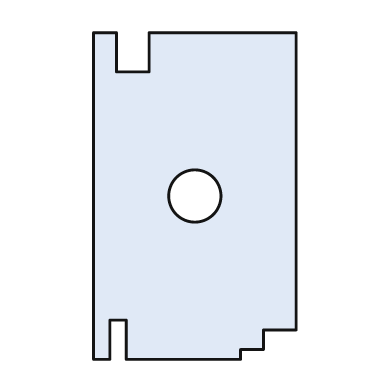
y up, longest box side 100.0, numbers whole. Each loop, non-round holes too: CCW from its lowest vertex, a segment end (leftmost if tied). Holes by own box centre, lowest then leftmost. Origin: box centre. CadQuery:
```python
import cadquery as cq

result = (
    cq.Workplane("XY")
    .moveTo(-31.0, -50.0)
    .lineTo(-26.0, -50.0)
    .lineTo(-26.0, -38.0)
    .lineTo(-21.0, -38.0)
    .lineTo(-21.0, -50.0)
    .lineTo(14.0, -50.0)
    .lineTo(14.0, -47.0)
    .lineTo(21.0, -47.0)
    .lineTo(21.0, -41.0)
    .lineTo(31.0, -41.0)
    .lineTo(31.0, 50.0)
    .lineTo(-14.0, 50.0)
    .lineTo(-14.0, 38.0)
    .lineTo(-24.0, 38.0)
    .lineTo(-24.0, 50.0)
    .lineTo(-31.0, 50.0)
    .close()
    .moveTo(0.0, 0.0)
    .circle(8.0)
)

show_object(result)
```